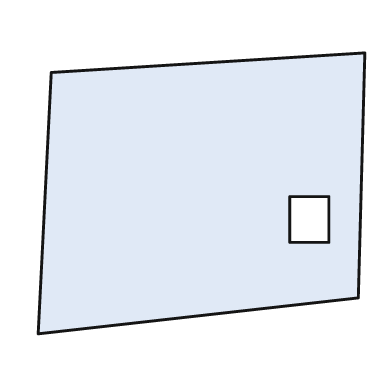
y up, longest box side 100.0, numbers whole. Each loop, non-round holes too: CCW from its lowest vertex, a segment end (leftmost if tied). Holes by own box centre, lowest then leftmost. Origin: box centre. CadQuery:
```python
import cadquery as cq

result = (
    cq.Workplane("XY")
    .moveTo(-50.0, -43.0)
    .lineTo(48.0, -32.0)
    .lineTo(50.0, 43.0)
    .lineTo(-46.0, 37.0)
    .close()
    .moveTo(27.0, -15.0)
    .lineTo(39.0, -15.0)
    .lineTo(39.0, -1.0)
    .lineTo(27.0, -1.0)
    .close()
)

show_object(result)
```